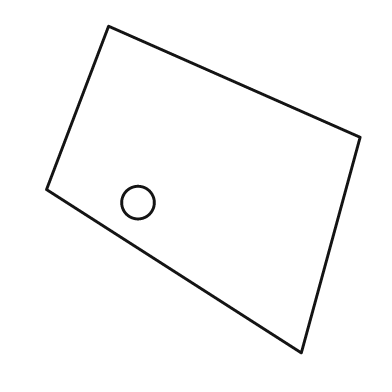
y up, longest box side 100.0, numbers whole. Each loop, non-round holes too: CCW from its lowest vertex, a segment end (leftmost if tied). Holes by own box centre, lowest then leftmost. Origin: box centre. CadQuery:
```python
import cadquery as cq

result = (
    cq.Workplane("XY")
    .moveTo(30.0, -50.0)
    .lineTo(48.0, 16.0)
    .lineTo(-29.0, 50.0)
    .lineTo(-48.0, 0.0)
    .close()
    .moveTo(-20.0, -4.0)
    .circle(5.0)
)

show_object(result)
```